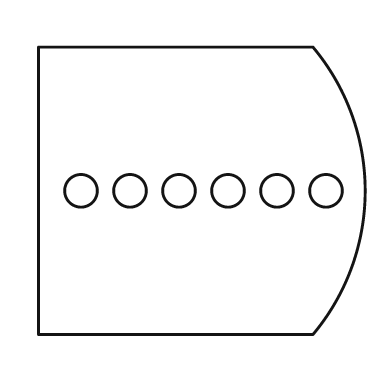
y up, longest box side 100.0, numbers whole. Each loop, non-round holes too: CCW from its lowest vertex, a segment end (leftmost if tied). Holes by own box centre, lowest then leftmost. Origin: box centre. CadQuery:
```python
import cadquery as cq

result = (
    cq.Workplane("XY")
    .moveTo(-50.0, -44.0)
    .lineTo(34.0, -44.0)
    .threePointArc((50.0, 0.0), (34.0, 44.0))
    .lineTo(-50.0, 44.0)
    .close()
    .moveTo(-37.0, 0.0)
    .circle(5.0)
    .moveTo(-22.0, 0.0)
    .circle(5.0)
    .moveTo(-7.0, 0.0)
    .circle(5.0)
    .moveTo(8.0, 0.0)
    .circle(5.0)
    .moveTo(23.0, 0.0)
    .circle(5.0)
    .moveTo(38.0, 0.0)
    .circle(5.0)
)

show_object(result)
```